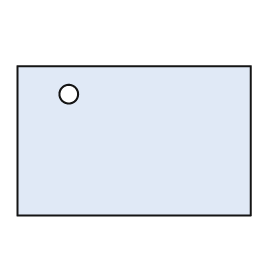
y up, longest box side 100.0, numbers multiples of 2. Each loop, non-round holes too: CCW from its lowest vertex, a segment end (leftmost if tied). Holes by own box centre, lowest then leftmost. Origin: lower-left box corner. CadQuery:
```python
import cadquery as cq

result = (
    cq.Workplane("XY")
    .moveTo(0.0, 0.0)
    .lineTo(100.0, 0.0)
    .lineTo(100.0, 64.0)
    .lineTo(0.0, 64.0)
    .close()
    .moveTo(22.0, 52.0)
    .circle(4.0)
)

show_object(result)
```